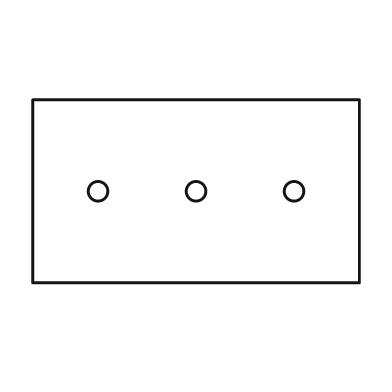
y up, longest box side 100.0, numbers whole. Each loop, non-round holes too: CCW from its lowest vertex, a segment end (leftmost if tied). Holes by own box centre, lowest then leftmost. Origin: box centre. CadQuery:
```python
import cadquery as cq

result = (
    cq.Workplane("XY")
    .moveTo(-50.0, -28.0)
    .lineTo(50.0, -28.0)
    .lineTo(50.0, 28.0)
    .lineTo(-50.0, 28.0)
    .close()
    .moveTo(-30.0, 0.0)
    .circle(3.0)
    .moveTo(0.0, 0.0)
    .circle(3.0)
    .moveTo(30.0, 0.0)
    .circle(3.0)
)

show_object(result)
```